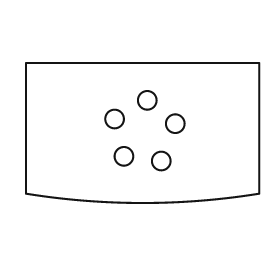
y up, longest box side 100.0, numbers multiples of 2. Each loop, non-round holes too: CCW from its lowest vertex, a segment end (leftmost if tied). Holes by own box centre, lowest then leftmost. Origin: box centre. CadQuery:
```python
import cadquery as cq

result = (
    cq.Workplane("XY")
    .moveTo(-50.0, -26.0)
    .threePointArc((0.0, -30.0), (50.0, -26.0))
    .lineTo(50.0, 30.0)
    .lineTo(-50.0, 30.0)
    .close()
    .moveTo(8.0, -12.0)
    .circle(4.0)
    .moveTo(-8.0, -10.0)
    .circle(4.0)
    .moveTo(14.0, 4.0)
    .circle(4.0)
    .moveTo(-12.0, 6.0)
    .circle(4.0)
    .moveTo(2.0, 14.0)
    .circle(4.0)
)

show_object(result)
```